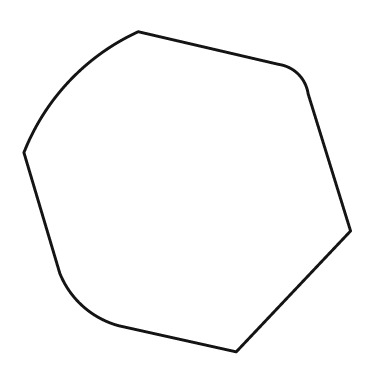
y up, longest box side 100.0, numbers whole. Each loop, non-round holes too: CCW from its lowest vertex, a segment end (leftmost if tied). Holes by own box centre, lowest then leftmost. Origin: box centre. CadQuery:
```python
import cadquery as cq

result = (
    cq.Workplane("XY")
    .moveTo(15.0, -49.0)
    .lineTo(50.0, -12.0)
    .lineTo(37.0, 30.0)
    .threePointArc((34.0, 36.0), (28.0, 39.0))
    .lineTo(-15.0, 49.0)
    .threePointArc((-36.0, 34.0), (-50.0, 12.0))
    .lineTo(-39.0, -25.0)
    .threePointArc((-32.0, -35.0), (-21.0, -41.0))
    .close()
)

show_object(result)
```